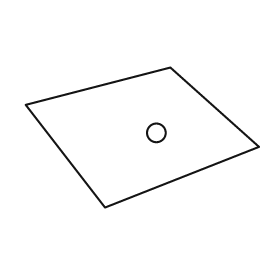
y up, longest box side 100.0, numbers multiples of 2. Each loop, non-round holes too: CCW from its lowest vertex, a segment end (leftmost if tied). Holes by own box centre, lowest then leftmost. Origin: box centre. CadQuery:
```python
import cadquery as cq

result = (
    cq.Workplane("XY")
    .moveTo(-16.0, -30.0)
    .lineTo(50.0, -4.0)
    .lineTo(12.0, 30.0)
    .lineTo(-50.0, 14.0)
    .close()
    .moveTo(6.0, 2.0)
    .circle(4.0)
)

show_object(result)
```